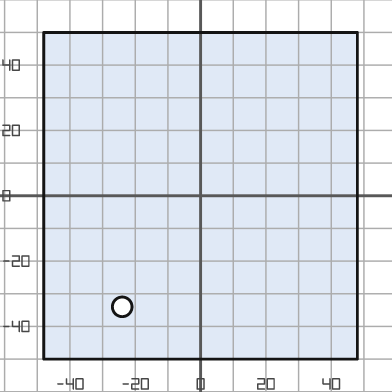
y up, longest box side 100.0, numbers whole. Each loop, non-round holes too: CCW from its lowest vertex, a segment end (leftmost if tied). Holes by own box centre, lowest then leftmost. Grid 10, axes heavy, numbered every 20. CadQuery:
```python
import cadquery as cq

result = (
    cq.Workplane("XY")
    .moveTo(-48.0, -50.0)
    .lineTo(48.0, -50.0)
    .lineTo(48.0, 50.0)
    .lineTo(-48.0, 50.0)
    .close()
    .moveTo(-24.0, -34.0)
    .circle(3.0)
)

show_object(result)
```